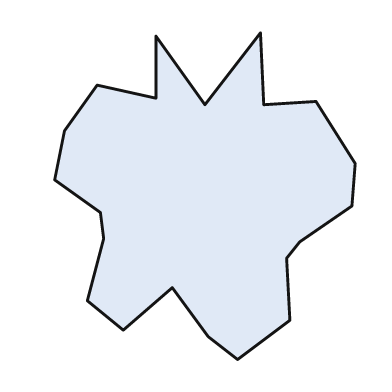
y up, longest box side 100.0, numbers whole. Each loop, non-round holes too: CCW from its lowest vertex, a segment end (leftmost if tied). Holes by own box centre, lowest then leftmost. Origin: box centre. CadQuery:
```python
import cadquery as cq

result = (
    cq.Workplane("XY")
    .moveTo(10.0, -50.0)
    .lineTo(26.0, -38.0)
    .lineTo(25.0, -19.0)
    .lineTo(29.0, -14.0)
    .lineTo(45.0, -3.0)
    .lineTo(46.0, 10.0)
    .lineTo(34.0, 29.0)
    .lineTo(18.0, 28.0)
    .lineTo(17.0, 50.0)
    .lineTo(0.0, 28.0)
    .lineTo(-15.0, 49.0)
    .lineTo(-15.0, 30.0)
    .lineTo(-33.0, 34.0)
    .lineTo(-43.0, 20.0)
    .lineTo(-46.0, 5.0)
    .lineTo(-32.0, -5.0)
    .lineTo(-31.0, -13.0)
    .lineTo(-36.0, -32.0)
    .lineTo(-25.0, -41.0)
    .lineTo(-10.0, -28.0)
    .lineTo(1.0, -43.0)
    .close()
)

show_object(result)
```